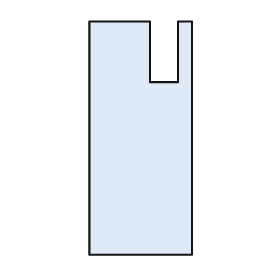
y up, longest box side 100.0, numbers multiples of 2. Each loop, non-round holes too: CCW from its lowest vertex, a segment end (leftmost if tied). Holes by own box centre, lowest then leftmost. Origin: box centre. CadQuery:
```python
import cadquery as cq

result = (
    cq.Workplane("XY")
    .moveTo(-22.0, -50.0)
    .lineTo(22.0, -50.0)
    .lineTo(22.0, 50.0)
    .lineTo(16.0, 50.0)
    .lineTo(16.0, 24.0)
    .lineTo(4.0, 24.0)
    .lineTo(4.0, 50.0)
    .lineTo(-22.0, 50.0)
    .close()
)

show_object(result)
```